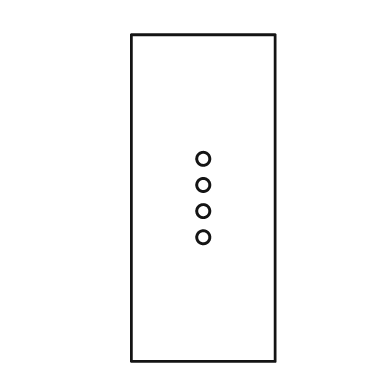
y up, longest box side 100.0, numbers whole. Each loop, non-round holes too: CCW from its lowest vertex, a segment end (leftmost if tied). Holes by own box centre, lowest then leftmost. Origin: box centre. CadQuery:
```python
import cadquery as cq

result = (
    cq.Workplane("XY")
    .moveTo(-22.0, -50.0)
    .lineTo(22.0, -50.0)
    .lineTo(22.0, 50.0)
    .lineTo(-22.0, 50.0)
    .close()
    .moveTo(0.0, -12.0)
    .circle(2.0)
    .moveTo(0.0, -4.0)
    .circle(2.0)
    .moveTo(0.0, 4.0)
    .circle(2.0)
    .moveTo(0.0, 12.0)
    .circle(2.0)
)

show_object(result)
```